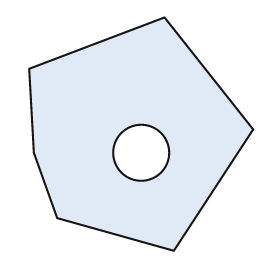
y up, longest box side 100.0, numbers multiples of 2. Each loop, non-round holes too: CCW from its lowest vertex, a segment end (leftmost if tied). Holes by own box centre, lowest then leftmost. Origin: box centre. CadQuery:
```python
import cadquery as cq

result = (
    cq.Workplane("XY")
    .moveTo(14.0, -50.0)
    .lineTo(48.0, 2.0)
    .lineTo(10.0, 50.0)
    .lineTo(-48.0, 28.0)
    .lineTo(-46.0, -8.0)
    .lineTo(-36.0, -36.0)
    .close()
    .moveTo(0.0, -8.0)
    .circle(12.0)
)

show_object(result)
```